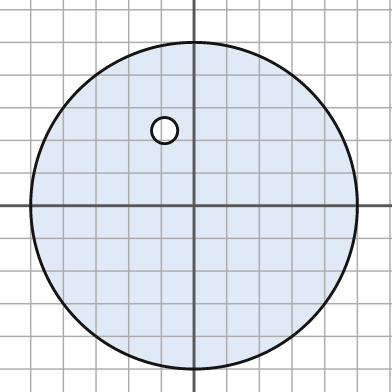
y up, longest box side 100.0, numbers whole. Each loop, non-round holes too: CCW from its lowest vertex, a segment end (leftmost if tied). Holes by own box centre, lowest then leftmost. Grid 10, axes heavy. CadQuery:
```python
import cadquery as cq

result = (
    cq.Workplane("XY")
    .moveTo(0.0, 0.0)
    .circle(50.0)
    .moveTo(-9.0, 23.0)
    .circle(4.0)
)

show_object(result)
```